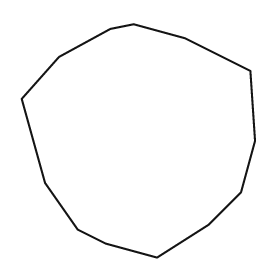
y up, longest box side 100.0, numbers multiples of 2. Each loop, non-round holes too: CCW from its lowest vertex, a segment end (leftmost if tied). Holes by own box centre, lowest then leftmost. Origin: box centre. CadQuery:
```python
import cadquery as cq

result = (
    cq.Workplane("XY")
    .moveTo(8.0, -50.0)
    .lineTo(30.0, -36.0)
    .lineTo(44.0, -22.0)
    .lineTo(50.0, 0.0)
    .lineTo(48.0, 30.0)
    .lineTo(20.0, 44.0)
    .lineTo(-2.0, 50.0)
    .lineTo(-12.0, 48.0)
    .lineTo(-34.0, 36.0)
    .lineTo(-50.0, 18.0)
    .lineTo(-40.0, -18.0)
    .lineTo(-26.0, -38.0)
    .lineTo(-14.0, -44.0)
    .close()
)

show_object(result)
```